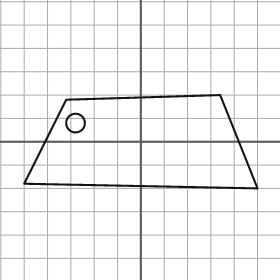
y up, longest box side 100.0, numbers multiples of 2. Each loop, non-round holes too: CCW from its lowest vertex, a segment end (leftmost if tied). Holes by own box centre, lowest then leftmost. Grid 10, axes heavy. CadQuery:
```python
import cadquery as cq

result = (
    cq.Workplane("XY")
    .moveTo(50.0, -20.0)
    .lineTo(34.0, 20.0)
    .lineTo(-32.0, 18.0)
    .lineTo(-50.0, -18.0)
    .close()
    .moveTo(-28.0, 8.0)
    .circle(4.0)
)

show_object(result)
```